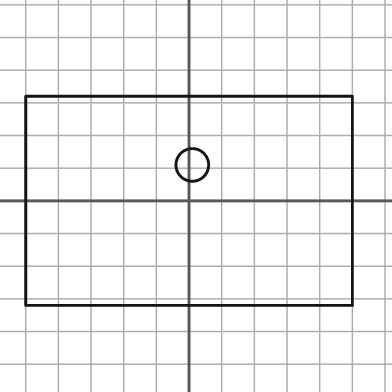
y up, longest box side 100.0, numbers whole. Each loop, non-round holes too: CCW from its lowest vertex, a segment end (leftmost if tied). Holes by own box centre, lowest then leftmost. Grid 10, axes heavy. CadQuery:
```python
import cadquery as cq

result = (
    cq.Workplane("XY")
    .moveTo(-50.0, -32.0)
    .lineTo(50.0, -32.0)
    .lineTo(50.0, 32.0)
    .lineTo(-50.0, 32.0)
    .close()
    .moveTo(1.0, 11.0)
    .circle(5.0)
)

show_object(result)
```